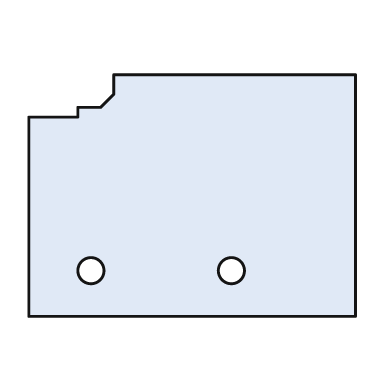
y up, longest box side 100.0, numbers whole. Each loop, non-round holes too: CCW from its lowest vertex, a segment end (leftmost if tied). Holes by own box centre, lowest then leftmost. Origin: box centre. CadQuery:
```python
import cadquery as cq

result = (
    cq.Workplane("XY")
    .moveTo(-50.0, -37.0)
    .lineTo(50.0, -37.0)
    .lineTo(50.0, 37.0)
    .lineTo(-24.0, 37.0)
    .lineTo(-24.0, 31.0)
    .lineTo(-28.0, 27.0)
    .lineTo(-35.0, 27.0)
    .lineTo(-35.0, 24.0)
    .lineTo(-50.0, 24.0)
    .close()
    .moveTo(-31.0, -23.0)
    .circle(4.0)
    .moveTo(12.0, -23.0)
    .circle(4.0)
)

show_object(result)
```